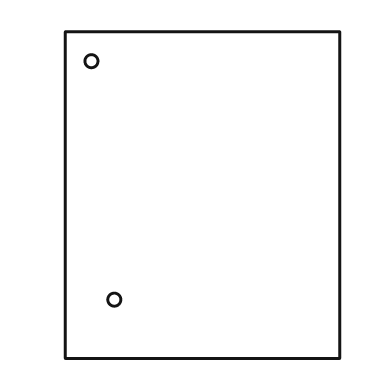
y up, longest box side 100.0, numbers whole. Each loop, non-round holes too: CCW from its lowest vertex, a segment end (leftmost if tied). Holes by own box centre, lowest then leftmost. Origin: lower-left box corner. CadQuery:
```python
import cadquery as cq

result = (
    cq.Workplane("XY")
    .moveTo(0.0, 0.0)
    .lineTo(84.0, 0.0)
    .lineTo(84.0, 100.0)
    .lineTo(0.0, 100.0)
    .close()
    .moveTo(15.0, 18.0)
    .circle(2.0)
    .moveTo(8.0, 91.0)
    .circle(2.0)
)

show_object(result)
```